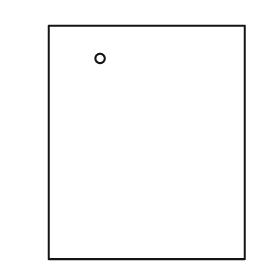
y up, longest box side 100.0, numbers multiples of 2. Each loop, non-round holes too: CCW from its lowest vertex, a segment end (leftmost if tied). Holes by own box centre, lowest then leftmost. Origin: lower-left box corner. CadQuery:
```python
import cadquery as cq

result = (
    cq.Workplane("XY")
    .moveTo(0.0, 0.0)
    .lineTo(84.0, 0.0)
    .lineTo(84.0, 100.0)
    .lineTo(0.0, 100.0)
    .close()
    .moveTo(22.0, 86.0)
    .circle(2.0)
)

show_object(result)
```